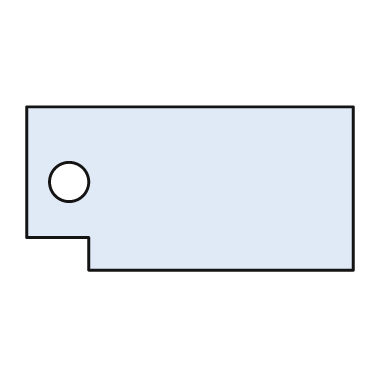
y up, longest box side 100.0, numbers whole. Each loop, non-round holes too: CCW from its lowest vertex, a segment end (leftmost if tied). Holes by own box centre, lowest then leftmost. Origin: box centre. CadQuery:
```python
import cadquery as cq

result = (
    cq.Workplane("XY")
    .moveTo(-31.0, -25.0)
    .lineTo(50.0, -25.0)
    .lineTo(50.0, 25.0)
    .lineTo(-50.0, 25.0)
    .lineTo(-50.0, -15.0)
    .lineTo(-31.0, -15.0)
    .close()
    .moveTo(-37.0, 2.0)
    .circle(6.0)
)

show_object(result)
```